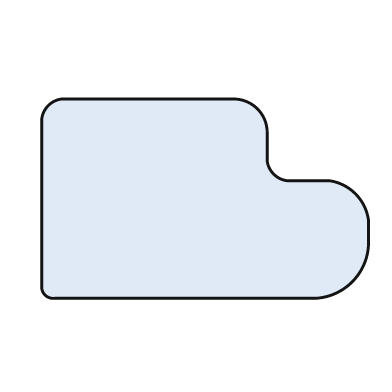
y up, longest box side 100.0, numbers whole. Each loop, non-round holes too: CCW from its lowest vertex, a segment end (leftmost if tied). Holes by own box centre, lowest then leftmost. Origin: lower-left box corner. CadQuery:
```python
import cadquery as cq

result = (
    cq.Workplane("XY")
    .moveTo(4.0, 0.0)
    .lineTo(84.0, 0.0)
    .threePointArc((95.0, 5.0), (100.0, 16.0))
    .lineTo(100.0, 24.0)
    .threePointArc((96.0, 32.0), (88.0, 36.0))
    .lineTo(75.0, 36.0)
    .threePointArc((71.0, 38.0), (69.0, 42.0))
    .lineTo(69.0, 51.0)
    .threePointArc((66.0, 58.0), (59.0, 61.0))
    .lineTo(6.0, 61.0)
    .threePointArc((2.0, 59.0), (0.0, 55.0))
    .lineTo(0.0, 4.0)
    .threePointArc((1.0, 1.0), (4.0, 0.0))
    .close()
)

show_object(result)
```